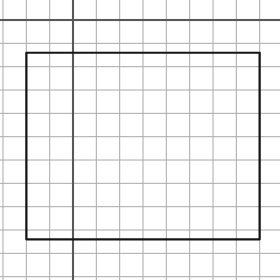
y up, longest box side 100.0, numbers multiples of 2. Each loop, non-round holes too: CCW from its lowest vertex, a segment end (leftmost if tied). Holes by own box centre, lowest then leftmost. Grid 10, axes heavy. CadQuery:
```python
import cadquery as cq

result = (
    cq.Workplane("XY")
    .moveTo(-20.0, -94.0)
    .lineTo(80.0, -94.0)
    .lineTo(80.0, -14.0)
    .lineTo(-20.0, -14.0)
    .close()
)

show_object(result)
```